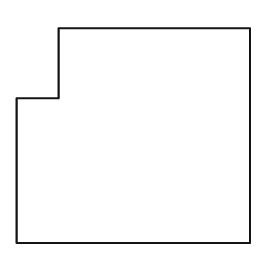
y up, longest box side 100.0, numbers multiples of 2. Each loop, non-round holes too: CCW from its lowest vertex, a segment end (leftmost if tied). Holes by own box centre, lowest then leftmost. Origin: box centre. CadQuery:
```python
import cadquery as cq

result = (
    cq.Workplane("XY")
    .moveTo(-50.0, -46.0)
    .lineTo(50.0, -46.0)
    .lineTo(50.0, 46.0)
    .lineTo(-32.0, 46.0)
    .lineTo(-32.0, 16.0)
    .lineTo(-50.0, 16.0)
    .close()
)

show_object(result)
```